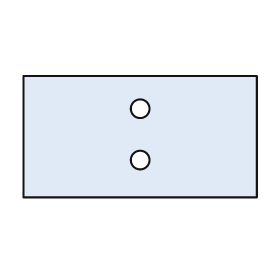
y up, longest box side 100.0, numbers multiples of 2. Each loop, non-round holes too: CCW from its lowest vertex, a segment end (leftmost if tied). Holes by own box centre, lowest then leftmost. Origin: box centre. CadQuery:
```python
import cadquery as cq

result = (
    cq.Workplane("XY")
    .moveTo(-50.0, -26.0)
    .lineTo(50.0, -26.0)
    .lineTo(50.0, 26.0)
    .lineTo(-50.0, 26.0)
    .close()
    .moveTo(0.0, -10.0)
    .circle(4.0)
    .moveTo(0.0, 12.0)
    .circle(4.0)
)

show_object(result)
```